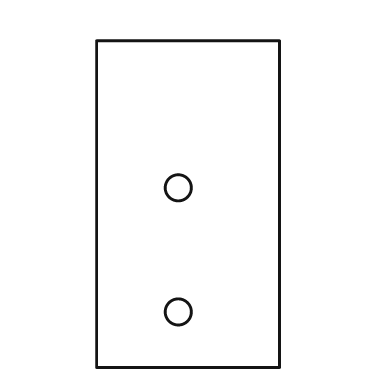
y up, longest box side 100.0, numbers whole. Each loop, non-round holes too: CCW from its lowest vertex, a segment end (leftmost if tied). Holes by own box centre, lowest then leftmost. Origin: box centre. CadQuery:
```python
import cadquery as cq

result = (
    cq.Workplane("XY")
    .moveTo(-28.0, -50.0)
    .lineTo(28.0, -50.0)
    .lineTo(28.0, 50.0)
    .lineTo(-28.0, 50.0)
    .close()
    .moveTo(-3.0, -33.0)
    .circle(4.0)
    .moveTo(-3.0, 5.0)
    .circle(4.0)
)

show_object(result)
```